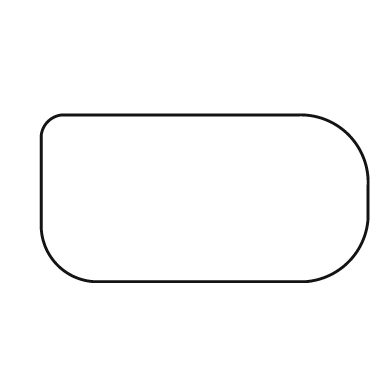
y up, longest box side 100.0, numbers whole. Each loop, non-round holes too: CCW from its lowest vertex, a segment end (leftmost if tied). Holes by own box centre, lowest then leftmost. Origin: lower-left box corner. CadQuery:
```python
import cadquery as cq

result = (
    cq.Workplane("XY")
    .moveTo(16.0, 0.0)
    .lineTo(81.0, 0.0)
    .threePointArc((94.0, 6.0), (100.0, 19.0))
    .lineTo(100.0, 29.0)
    .threePointArc((94.0, 45.0), (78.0, 51.0))
    .lineTo(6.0, 51.0)
    .threePointArc((2.0, 49.0), (0.0, 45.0))
    .lineTo(0.0, 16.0)
    .threePointArc((5.0, 5.0), (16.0, 0.0))
    .close()
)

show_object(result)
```